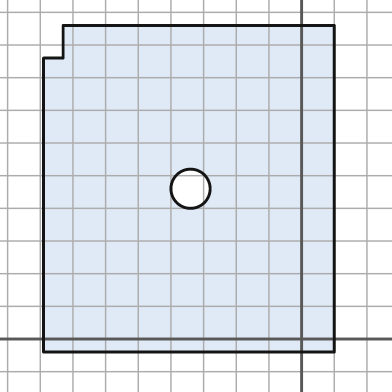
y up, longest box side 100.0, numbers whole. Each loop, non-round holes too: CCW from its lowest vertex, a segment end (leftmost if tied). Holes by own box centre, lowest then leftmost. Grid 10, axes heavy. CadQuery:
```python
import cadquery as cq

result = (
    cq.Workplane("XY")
    .moveTo(-79.0, -4.0)
    .lineTo(10.0, -4.0)
    .lineTo(10.0, 96.0)
    .lineTo(-73.0, 96.0)
    .lineTo(-73.0, 86.0)
    .lineTo(-79.0, 86.0)
    .close()
    .moveTo(-34.0, 46.0)
    .circle(6.0)
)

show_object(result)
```